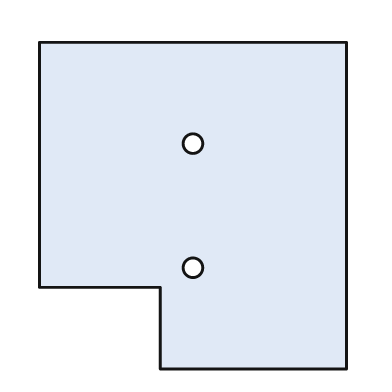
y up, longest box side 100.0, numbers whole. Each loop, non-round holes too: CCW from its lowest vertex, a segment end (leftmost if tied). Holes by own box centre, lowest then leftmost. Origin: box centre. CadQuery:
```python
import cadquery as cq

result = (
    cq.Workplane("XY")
    .moveTo(-10.0, -50.0)
    .lineTo(47.0, -50.0)
    .lineTo(47.0, 50.0)
    .lineTo(-47.0, 50.0)
    .lineTo(-47.0, -25.0)
    .lineTo(-10.0, -25.0)
    .close()
    .moveTo(0.0, -19.0)
    .circle(3.0)
    .moveTo(0.0, 19.0)
    .circle(3.0)
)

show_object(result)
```